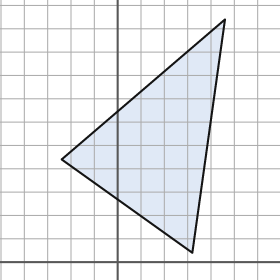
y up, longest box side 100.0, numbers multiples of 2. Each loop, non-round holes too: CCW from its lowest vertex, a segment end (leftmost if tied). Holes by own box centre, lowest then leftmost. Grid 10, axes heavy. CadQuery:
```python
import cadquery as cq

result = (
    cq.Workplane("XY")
    .moveTo(32.0, 4.0)
    .lineTo(46.0, 104.0)
    .lineTo(-24.0, 44.0)
    .close()
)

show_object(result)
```